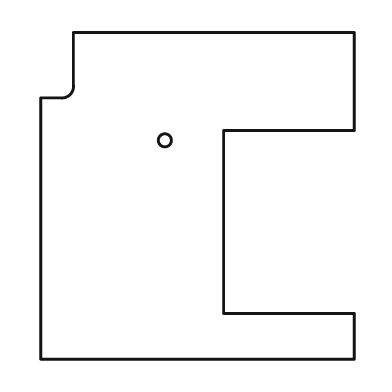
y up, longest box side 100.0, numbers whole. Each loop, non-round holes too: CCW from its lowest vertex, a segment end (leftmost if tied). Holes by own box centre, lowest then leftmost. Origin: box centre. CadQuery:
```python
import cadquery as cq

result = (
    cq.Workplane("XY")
    .moveTo(-48.0, -50.0)
    .lineTo(48.0, -50.0)
    .lineTo(48.0, -36.0)
    .lineTo(8.0, -36.0)
    .lineTo(8.0, 20.0)
    .lineTo(48.0, 20.0)
    .lineTo(48.0, 50.0)
    .lineTo(-38.0, 50.0)
    .lineTo(-38.0, 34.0)
    .threePointArc((-39.0, 31.0), (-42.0, 30.0))
    .lineTo(-48.0, 30.0)
    .close()
    .moveTo(-10.0, 17.0)
    .circle(2.0)
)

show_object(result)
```